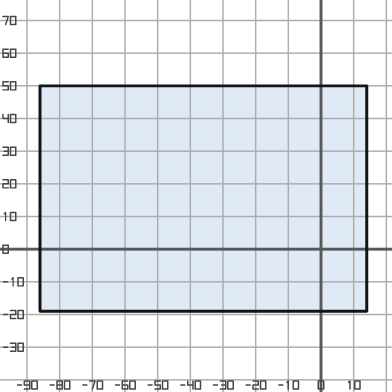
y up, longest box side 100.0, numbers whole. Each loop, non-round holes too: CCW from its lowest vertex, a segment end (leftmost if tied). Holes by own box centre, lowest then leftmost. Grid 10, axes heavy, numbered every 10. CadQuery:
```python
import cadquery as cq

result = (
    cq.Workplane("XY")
    .moveTo(-86.0, -19.0)
    .lineTo(14.0, -19.0)
    .lineTo(14.0, 50.0)
    .lineTo(-86.0, 50.0)
    .close()
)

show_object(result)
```